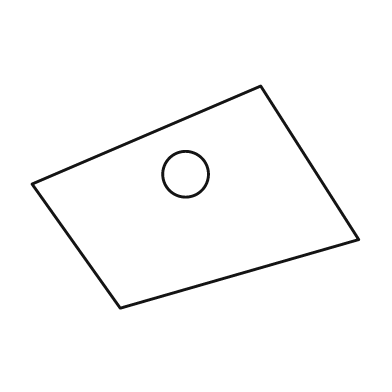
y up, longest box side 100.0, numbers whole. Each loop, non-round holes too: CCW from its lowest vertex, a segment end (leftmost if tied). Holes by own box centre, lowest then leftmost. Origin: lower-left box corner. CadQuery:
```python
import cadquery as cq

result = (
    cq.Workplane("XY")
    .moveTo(27.0, 0.0)
    .lineTo(100.0, 21.0)
    .lineTo(70.0, 68.0)
    .lineTo(0.0, 38.0)
    .close()
    .moveTo(47.0, 41.0)
    .circle(7.0)
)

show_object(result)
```